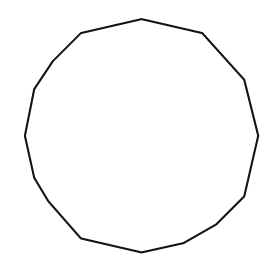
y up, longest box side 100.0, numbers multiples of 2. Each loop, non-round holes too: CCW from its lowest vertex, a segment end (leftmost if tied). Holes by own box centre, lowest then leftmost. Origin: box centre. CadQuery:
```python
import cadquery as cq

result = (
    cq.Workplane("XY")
    .moveTo(0.0, -50.0)
    .lineTo(18.0, -46.0)
    .lineTo(32.0, -38.0)
    .lineTo(44.0, -26.0)
    .lineTo(50.0, 0.0)
    .lineTo(44.0, 24.0)
    .lineTo(26.0, 44.0)
    .lineTo(0.0, 50.0)
    .lineTo(-26.0, 44.0)
    .lineTo(-38.0, 32.0)
    .lineTo(-46.0, 20.0)
    .lineTo(-50.0, 0.0)
    .lineTo(-46.0, -18.0)
    .lineTo(-40.0, -28.0)
    .lineTo(-26.0, -44.0)
    .close()
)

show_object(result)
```